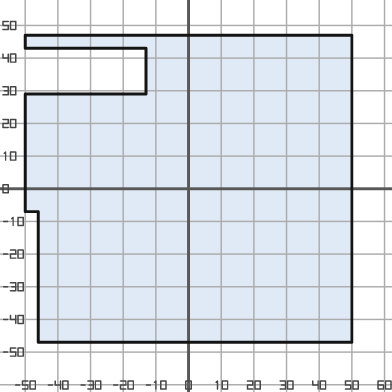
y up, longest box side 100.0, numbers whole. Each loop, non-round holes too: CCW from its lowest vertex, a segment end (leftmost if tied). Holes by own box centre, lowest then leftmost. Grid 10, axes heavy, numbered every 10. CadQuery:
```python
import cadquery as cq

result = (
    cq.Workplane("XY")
    .moveTo(-46.0, -47.0)
    .lineTo(50.0, -47.0)
    .lineTo(50.0, 47.0)
    .lineTo(-50.0, 47.0)
    .lineTo(-50.0, 43.0)
    .lineTo(-13.0, 43.0)
    .lineTo(-13.0, 29.0)
    .lineTo(-50.0, 29.0)
    .lineTo(-50.0, -7.0)
    .lineTo(-46.0, -7.0)
    .close()
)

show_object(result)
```